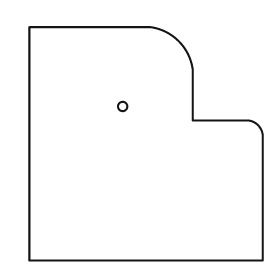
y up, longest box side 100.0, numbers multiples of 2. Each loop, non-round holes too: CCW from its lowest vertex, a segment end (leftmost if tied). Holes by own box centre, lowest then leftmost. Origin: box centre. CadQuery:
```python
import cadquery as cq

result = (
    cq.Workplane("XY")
    .moveTo(-50.0, -50.0)
    .lineTo(50.0, -50.0)
    .lineTo(50.0, 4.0)
    .threePointArc((48.0, 8.0), (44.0, 10.0))
    .lineTo(20.0, 10.0)
    .lineTo(20.0, 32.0)
    .threePointArc((14.0, 44.0), (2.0, 50.0))
    .lineTo(-50.0, 50.0)
    .close()
    .moveTo(-10.0, 16.0)
    .circle(2.0)
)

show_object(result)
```